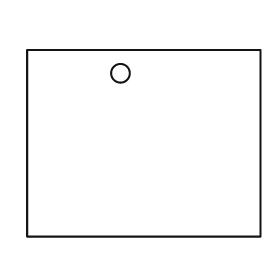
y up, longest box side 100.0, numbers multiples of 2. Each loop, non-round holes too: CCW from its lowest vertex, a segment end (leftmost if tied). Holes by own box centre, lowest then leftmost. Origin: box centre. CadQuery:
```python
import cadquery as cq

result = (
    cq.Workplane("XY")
    .moveTo(-50.0, -40.0)
    .lineTo(50.0, -40.0)
    .lineTo(50.0, 40.0)
    .lineTo(-50.0, 40.0)
    .close()
    .moveTo(-10.0, 30.0)
    .circle(4.0)
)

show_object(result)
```